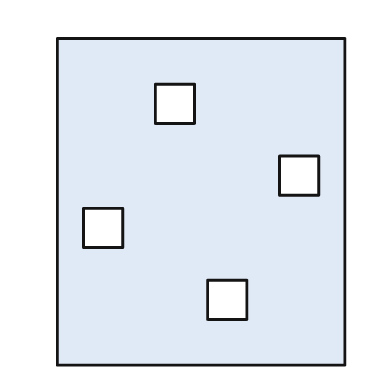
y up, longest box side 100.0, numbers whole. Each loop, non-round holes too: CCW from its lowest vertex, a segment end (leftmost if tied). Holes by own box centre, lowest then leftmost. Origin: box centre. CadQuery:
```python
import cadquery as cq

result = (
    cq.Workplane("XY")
    .moveTo(-44.0, -50.0)
    .lineTo(44.0, -50.0)
    .lineTo(44.0, 50.0)
    .lineTo(-44.0, 50.0)
    .close()
    .moveTo(2.0, -36.0)
    .lineTo(14.0, -36.0)
    .lineTo(14.0, -24.0)
    .lineTo(2.0, -24.0)
    .close()
    .moveTo(-36.0, -14.0)
    .lineTo(-24.0, -14.0)
    .lineTo(-24.0, -2.0)
    .lineTo(-36.0, -2.0)
    .close()
    .moveTo(24.0, 2.0)
    .lineTo(36.0, 2.0)
    .lineTo(36.0, 14.0)
    .lineTo(24.0, 14.0)
    .close()
    .moveTo(-14.0, 24.0)
    .lineTo(-2.0, 24.0)
    .lineTo(-2.0, 36.0)
    .lineTo(-14.0, 36.0)
    .close()
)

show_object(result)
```